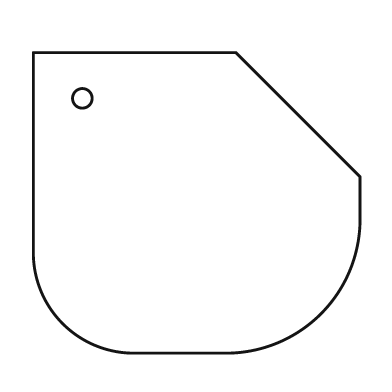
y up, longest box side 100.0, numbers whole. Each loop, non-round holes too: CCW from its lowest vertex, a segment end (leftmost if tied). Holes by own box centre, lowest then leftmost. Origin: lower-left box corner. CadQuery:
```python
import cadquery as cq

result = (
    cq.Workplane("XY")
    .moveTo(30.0, 0.0)
    .lineTo(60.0, 0.0)
    .threePointArc((88.0, 12.0), (100.0, 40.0))
    .lineTo(100.0, 54.0)
    .lineTo(62.0, 92.0)
    .lineTo(0.0, 92.0)
    .lineTo(0.0, 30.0)
    .threePointArc((9.0, 9.0), (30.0, 0.0))
    .close()
    .moveTo(15.0, 78.0)
    .circle(3.0)
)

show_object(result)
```